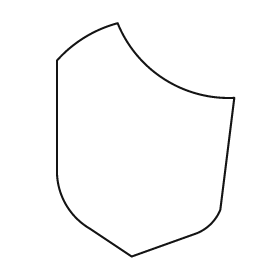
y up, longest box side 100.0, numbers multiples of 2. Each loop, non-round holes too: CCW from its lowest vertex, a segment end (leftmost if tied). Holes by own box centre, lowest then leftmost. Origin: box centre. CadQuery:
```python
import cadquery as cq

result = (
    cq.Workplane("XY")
    .moveTo(-6.0, -50.0)
    .lineTo(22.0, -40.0)
    .threePointArc((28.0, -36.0), (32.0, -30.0))
    .lineTo(38.0, 18.0)
    .threePointArc((8.0, 26.0), (-12.0, 50.0))
    .threePointArc((-26.0, 44.0), (-38.0, 34.0))
    .lineTo(-38.0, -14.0)
    .threePointArc((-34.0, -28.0), (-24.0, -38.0))
    .close()
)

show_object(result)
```